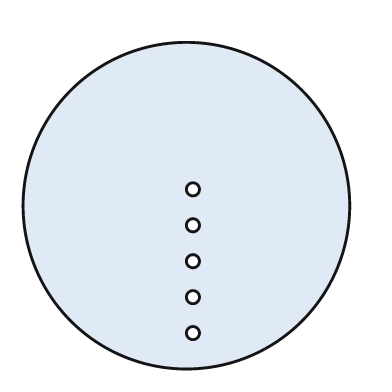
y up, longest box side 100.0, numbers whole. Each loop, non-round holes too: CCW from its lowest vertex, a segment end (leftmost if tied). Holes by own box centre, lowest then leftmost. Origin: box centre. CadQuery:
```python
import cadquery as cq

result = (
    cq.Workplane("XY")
    .moveTo(0.0, 0.0)
    .circle(50.0)
    .moveTo(2.0, -39.0)
    .circle(2.0)
    .moveTo(2.0, -28.0)
    .circle(2.0)
    .moveTo(2.0, -17.0)
    .circle(2.0)
    .moveTo(2.0, -6.0)
    .circle(2.0)
    .moveTo(2.0, 5.0)
    .circle(2.0)
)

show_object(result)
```